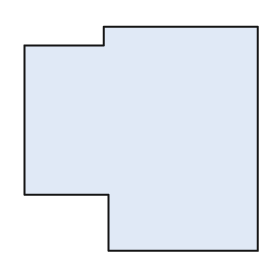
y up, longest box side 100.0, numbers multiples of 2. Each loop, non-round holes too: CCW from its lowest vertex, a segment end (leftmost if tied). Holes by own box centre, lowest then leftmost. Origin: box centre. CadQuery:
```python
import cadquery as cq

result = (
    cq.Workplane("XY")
    .moveTo(-14.0, -48.0)
    .lineTo(50.0, -48.0)
    .lineTo(50.0, 48.0)
    .lineTo(-16.0, 48.0)
    .lineTo(-16.0, 40.0)
    .lineTo(-50.0, 40.0)
    .lineTo(-50.0, -24.0)
    .lineTo(-14.0, -24.0)
    .close()
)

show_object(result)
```